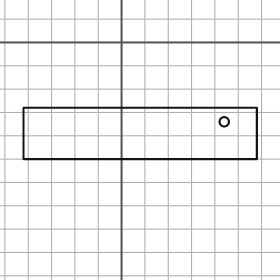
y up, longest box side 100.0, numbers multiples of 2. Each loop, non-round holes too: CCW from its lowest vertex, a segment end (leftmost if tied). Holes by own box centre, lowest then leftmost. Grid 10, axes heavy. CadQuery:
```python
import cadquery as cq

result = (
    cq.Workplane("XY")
    .moveTo(-42.0, -50.0)
    .lineTo(58.0, -50.0)
    .lineTo(58.0, -28.0)
    .lineTo(-42.0, -28.0)
    .close()
    .moveTo(44.0, -34.0)
    .circle(2.0)
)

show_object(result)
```